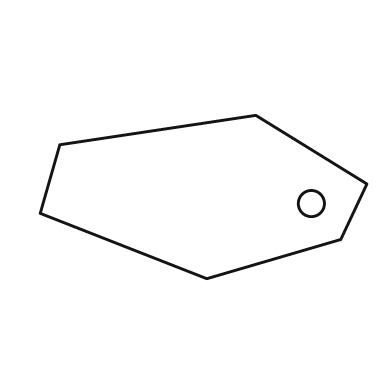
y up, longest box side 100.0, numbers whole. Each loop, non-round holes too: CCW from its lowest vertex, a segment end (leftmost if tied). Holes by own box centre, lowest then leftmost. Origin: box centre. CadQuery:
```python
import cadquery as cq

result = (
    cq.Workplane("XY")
    .moveTo(1.0, -25.0)
    .lineTo(42.0, -13.0)
    .lineTo(50.0, 4.0)
    .lineTo(16.0, 25.0)
    .lineTo(-44.0, 16.0)
    .lineTo(-50.0, -5.0)
    .close()
    .moveTo(33.0, -2.0)
    .circle(4.0)
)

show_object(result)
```